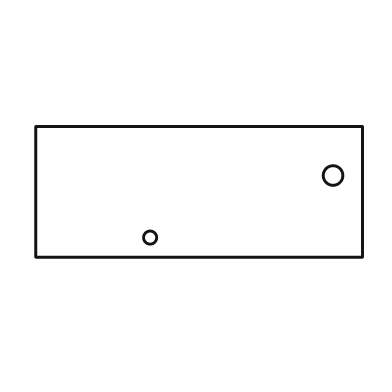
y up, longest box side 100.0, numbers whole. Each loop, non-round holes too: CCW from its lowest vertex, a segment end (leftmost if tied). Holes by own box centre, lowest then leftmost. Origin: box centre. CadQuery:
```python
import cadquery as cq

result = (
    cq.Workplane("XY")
    .moveTo(-50.0, -20.0)
    .lineTo(50.0, -20.0)
    .lineTo(50.0, 20.0)
    .lineTo(-50.0, 20.0)
    .close()
    .moveTo(-15.0, -14.0)
    .circle(2.0)
    .moveTo(41.0, 5.0)
    .circle(3.0)
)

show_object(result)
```